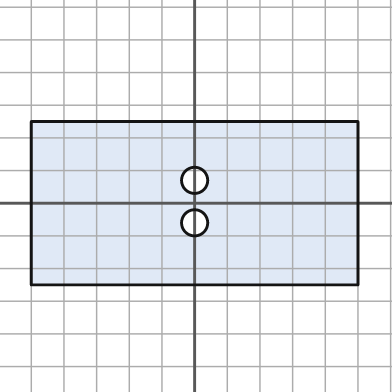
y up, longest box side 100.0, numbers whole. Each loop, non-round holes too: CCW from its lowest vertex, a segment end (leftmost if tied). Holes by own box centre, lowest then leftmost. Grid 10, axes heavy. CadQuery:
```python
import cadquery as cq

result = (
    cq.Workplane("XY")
    .moveTo(-50.0, -25.0)
    .lineTo(50.0, -25.0)
    .lineTo(50.0, 25.0)
    .lineTo(-50.0, 25.0)
    .close()
    .moveTo(0.0, -6.0)
    .circle(4.0)
    .moveTo(0.0, 7.0)
    .circle(4.0)
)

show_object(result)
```